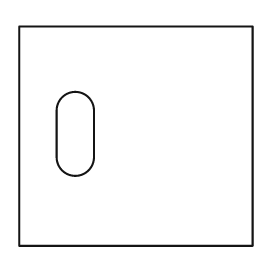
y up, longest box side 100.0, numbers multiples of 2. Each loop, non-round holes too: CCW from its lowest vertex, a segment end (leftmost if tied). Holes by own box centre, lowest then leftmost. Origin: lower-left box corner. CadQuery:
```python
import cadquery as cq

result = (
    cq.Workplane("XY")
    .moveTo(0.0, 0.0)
    .lineTo(100.0, 0.0)
    .lineTo(100.0, 94.0)
    .lineTo(0.0, 94.0)
    .close()
    .moveTo(16.0, 38.0)
    .threePointArc((24.0, 30.0), (32.0, 38.0))
    .lineTo(32.0, 58.0)
    .threePointArc((24.0, 66.0), (16.0, 58.0))
    .close()
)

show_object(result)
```